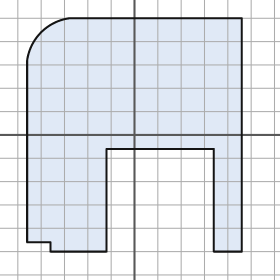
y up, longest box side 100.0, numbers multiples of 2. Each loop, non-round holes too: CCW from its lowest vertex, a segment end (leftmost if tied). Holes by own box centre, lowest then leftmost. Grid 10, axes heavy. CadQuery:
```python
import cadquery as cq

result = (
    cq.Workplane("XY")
    .moveTo(-36.0, -50.0)
    .lineTo(-12.0, -50.0)
    .lineTo(-12.0, -6.0)
    .lineTo(34.0, -6.0)
    .lineTo(34.0, -50.0)
    .lineTo(46.0, -50.0)
    .lineTo(46.0, 50.0)
    .lineTo(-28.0, 50.0)
    .threePointArc((-40.0, 44.0), (-46.0, 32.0))
    .lineTo(-46.0, -46.0)
    .lineTo(-36.0, -46.0)
    .close()
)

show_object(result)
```